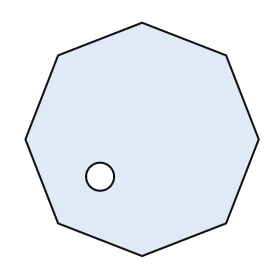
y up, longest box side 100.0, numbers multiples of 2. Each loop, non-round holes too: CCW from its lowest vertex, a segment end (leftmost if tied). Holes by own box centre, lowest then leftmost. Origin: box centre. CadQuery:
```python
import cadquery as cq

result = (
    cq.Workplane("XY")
    .moveTo(0.0, -50.0)
    .lineTo(36.0, -36.0)
    .lineTo(50.0, 0.0)
    .lineTo(36.0, 36.0)
    .lineTo(0.0, 50.0)
    .lineTo(-36.0, 36.0)
    .lineTo(-50.0, 0.0)
    .lineTo(-36.0, -36.0)
    .close()
    .moveTo(-18.0, -16.0)
    .circle(6.0)
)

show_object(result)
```